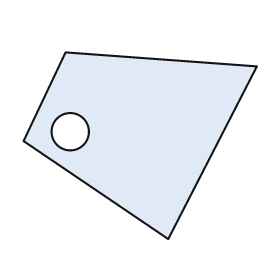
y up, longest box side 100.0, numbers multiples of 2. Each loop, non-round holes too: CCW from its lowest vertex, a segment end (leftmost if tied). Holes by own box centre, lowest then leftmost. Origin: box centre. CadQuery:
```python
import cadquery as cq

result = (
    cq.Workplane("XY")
    .moveTo(12.0, -40.0)
    .lineTo(50.0, 34.0)
    .lineTo(-32.0, 40.0)
    .lineTo(-50.0, 2.0)
    .close()
    .moveTo(-30.0, 6.0)
    .circle(8.0)
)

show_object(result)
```